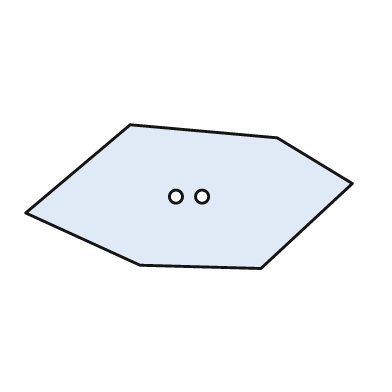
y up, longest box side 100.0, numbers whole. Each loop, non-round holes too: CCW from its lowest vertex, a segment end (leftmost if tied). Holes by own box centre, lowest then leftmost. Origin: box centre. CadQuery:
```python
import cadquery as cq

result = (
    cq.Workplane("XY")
    .moveTo(22.0, -22.0)
    .lineTo(50.0, 4.0)
    .lineTo(27.0, 18.0)
    .lineTo(-18.0, 22.0)
    .lineTo(-50.0, -5.0)
    .lineTo(-15.0, -21.0)
    .close()
    .moveTo(-4.0, 0.0)
    .circle(2.0)
    .moveTo(4.0, 0.0)
    .circle(2.0)
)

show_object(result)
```